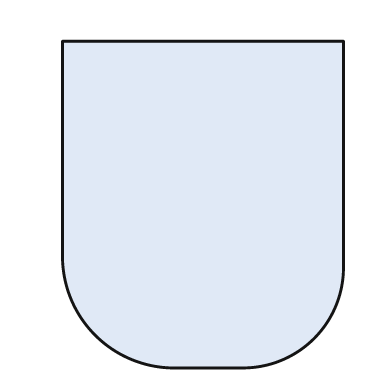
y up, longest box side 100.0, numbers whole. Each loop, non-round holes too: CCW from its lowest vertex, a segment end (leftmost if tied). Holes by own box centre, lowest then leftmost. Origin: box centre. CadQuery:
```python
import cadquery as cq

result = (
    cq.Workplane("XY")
    .moveTo(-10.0, -50.0)
    .lineTo(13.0, -50.0)
    .threePointArc((34.0, -41.0), (43.0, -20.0))
    .lineTo(43.0, 50.0)
    .lineTo(-43.0, 50.0)
    .lineTo(-43.0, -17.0)
    .threePointArc((-33.0, -40.0), (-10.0, -50.0))
    .close()
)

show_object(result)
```